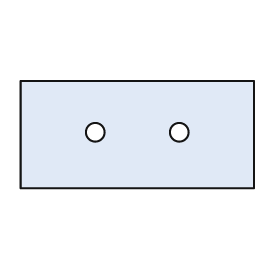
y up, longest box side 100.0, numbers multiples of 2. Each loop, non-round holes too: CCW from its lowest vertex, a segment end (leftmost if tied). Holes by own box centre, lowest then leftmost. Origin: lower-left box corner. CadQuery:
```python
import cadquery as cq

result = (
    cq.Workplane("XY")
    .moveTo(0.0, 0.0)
    .lineTo(100.0, 0.0)
    .lineTo(100.0, 46.0)
    .lineTo(0.0, 46.0)
    .close()
    .moveTo(32.0, 24.0)
    .circle(4.0)
    .moveTo(68.0, 24.0)
    .circle(4.0)
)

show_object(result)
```